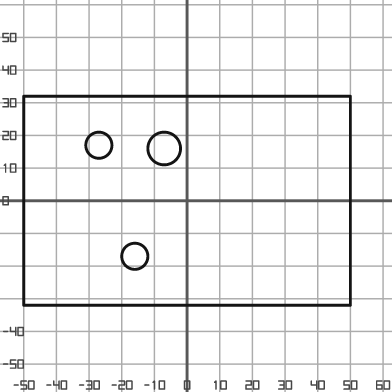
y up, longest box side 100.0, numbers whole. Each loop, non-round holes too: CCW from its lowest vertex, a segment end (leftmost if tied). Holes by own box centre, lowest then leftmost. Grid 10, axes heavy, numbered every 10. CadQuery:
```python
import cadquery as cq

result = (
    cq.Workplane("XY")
    .moveTo(-50.0, -32.0)
    .lineTo(50.0, -32.0)
    .lineTo(50.0, 32.0)
    .lineTo(-50.0, 32.0)
    .close()
    .moveTo(-16.0, -17.0)
    .circle(4.0)
    .moveTo(-7.0, 16.0)
    .circle(5.0)
    .moveTo(-27.0, 17.0)
    .circle(4.0)
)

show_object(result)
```